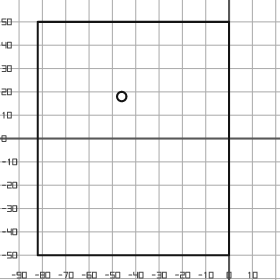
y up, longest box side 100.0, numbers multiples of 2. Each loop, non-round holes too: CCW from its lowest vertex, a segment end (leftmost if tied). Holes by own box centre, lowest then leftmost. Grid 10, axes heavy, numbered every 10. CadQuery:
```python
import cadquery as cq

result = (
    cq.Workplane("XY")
    .moveTo(-82.0, -50.0)
    .lineTo(0.0, -50.0)
    .lineTo(0.0, 50.0)
    .lineTo(-82.0, 50.0)
    .close()
    .moveTo(-46.0, 18.0)
    .circle(2.0)
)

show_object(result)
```